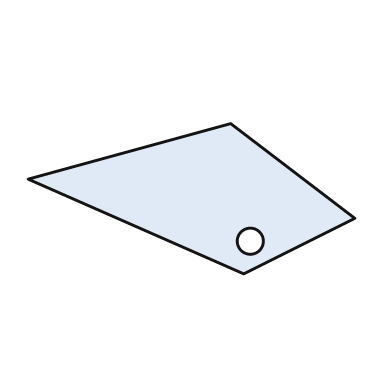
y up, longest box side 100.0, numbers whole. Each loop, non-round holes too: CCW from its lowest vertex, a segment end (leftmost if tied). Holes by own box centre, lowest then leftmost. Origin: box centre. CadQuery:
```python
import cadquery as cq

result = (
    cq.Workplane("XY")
    .moveTo(16.0, -23.0)
    .lineTo(50.0, -6.0)
    .lineTo(12.0, 23.0)
    .lineTo(-50.0, 6.0)
    .close()
    .moveTo(18.0, -13.0)
    .circle(4.0)
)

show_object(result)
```